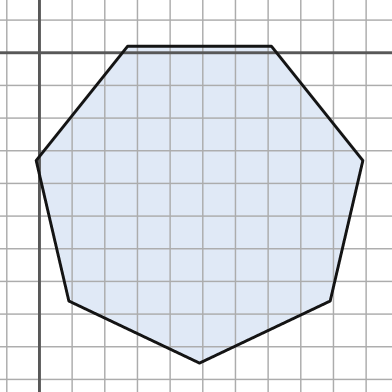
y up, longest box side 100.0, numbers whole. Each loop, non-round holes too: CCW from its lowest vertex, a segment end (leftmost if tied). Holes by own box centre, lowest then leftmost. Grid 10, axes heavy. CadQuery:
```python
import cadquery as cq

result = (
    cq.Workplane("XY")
    .moveTo(49.0, -95.0)
    .lineTo(89.0, -76.0)
    .lineTo(99.0, -33.0)
    .lineTo(71.0, 2.0)
    .lineTo(27.0, 2.0)
    .lineTo(-1.0, -33.0)
    .lineTo(9.0, -76.0)
    .close()
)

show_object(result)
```